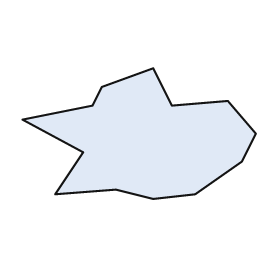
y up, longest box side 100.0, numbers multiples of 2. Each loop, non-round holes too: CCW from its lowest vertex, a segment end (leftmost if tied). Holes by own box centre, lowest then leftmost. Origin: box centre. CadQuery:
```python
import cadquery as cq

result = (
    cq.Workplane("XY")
    .moveTo(6.0, -28.0)
    .lineTo(24.0, -26.0)
    .lineTo(44.0, -12.0)
    .lineTo(50.0, 0.0)
    .lineTo(38.0, 14.0)
    .lineTo(14.0, 12.0)
    .lineTo(6.0, 28.0)
    .lineTo(-16.0, 20.0)
    .lineTo(-20.0, 12.0)
    .lineTo(-50.0, 6.0)
    .lineTo(-24.0, -8.0)
    .lineTo(-36.0, -26.0)
    .lineTo(-10.0, -24.0)
    .close()
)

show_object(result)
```